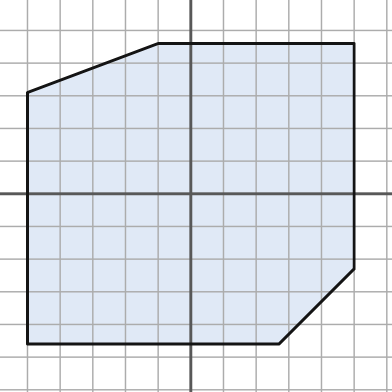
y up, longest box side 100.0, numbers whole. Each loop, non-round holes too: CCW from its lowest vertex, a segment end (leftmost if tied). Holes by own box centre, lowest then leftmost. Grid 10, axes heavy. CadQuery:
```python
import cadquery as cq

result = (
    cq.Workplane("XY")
    .moveTo(-50.0, -46.0)
    .lineTo(27.0, -46.0)
    .lineTo(50.0, -23.0)
    .lineTo(50.0, 46.0)
    .lineTo(-10.0, 46.0)
    .lineTo(-50.0, 31.0)
    .close()
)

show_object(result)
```